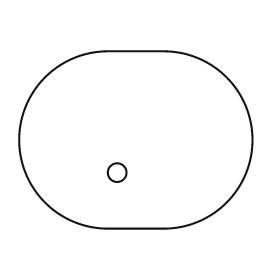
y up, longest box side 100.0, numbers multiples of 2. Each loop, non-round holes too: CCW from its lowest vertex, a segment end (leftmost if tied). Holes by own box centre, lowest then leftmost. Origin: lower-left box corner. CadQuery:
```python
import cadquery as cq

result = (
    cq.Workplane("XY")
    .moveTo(38.0, 0.0)
    .lineTo(62.0, 0.0)
    .threePointArc((100.0, 38.0), (62.0, 76.0))
    .lineTo(38.0, 76.0)
    .threePointArc((0.0, 38.0), (38.0, 0.0))
    .close()
    .moveTo(42.0, 24.0)
    .circle(4.0)
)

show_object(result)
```